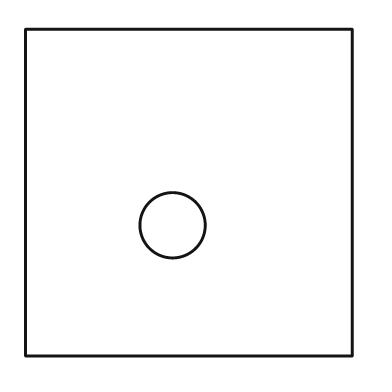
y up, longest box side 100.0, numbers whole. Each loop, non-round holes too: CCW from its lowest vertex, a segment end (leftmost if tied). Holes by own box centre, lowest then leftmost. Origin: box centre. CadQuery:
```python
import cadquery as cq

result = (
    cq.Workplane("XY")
    .moveTo(-50.0, -50.0)
    .lineTo(50.0, -50.0)
    .lineTo(50.0, 50.0)
    .lineTo(-50.0, 50.0)
    .close()
    .moveTo(-5.0, -10.0)
    .circle(10.0)
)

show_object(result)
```